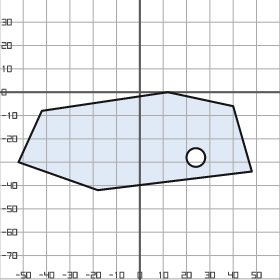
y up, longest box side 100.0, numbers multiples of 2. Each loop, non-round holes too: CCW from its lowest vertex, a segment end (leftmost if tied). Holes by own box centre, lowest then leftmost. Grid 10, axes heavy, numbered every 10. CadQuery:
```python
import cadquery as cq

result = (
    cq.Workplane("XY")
    .moveTo(-18.0, -42.0)
    .lineTo(48.0, -34.0)
    .lineTo(40.0, -6.0)
    .lineTo(12.0, 0.0)
    .lineTo(-42.0, -8.0)
    .lineTo(-52.0, -30.0)
    .close()
    .moveTo(24.0, -28.0)
    .circle(4.0)
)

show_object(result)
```